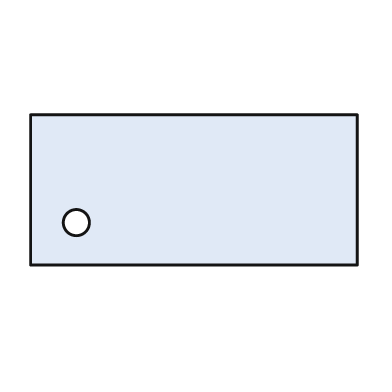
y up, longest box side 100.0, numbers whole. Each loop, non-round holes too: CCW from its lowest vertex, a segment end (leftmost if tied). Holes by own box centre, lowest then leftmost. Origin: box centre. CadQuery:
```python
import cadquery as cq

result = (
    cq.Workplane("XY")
    .moveTo(-50.0, -23.0)
    .lineTo(50.0, -23.0)
    .lineTo(50.0, 23.0)
    .lineTo(-50.0, 23.0)
    .close()
    .moveTo(-36.0, -10.0)
    .circle(4.0)
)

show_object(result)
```